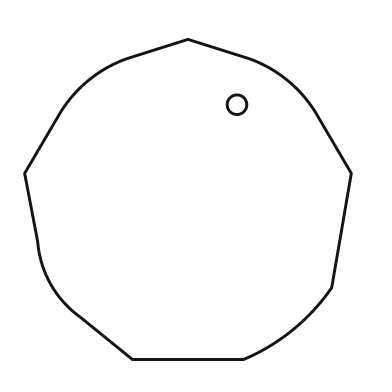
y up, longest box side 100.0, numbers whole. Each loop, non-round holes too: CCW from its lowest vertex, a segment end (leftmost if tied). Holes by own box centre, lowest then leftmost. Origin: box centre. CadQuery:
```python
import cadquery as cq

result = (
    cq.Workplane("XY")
    .moveTo(-17.0, -49.0)
    .lineTo(17.0, -49.0)
    .threePointArc((32.0, -40.0), (44.0, -27.0))
    .lineTo(50.0, 8.0)
    .lineTo(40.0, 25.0)
    .threePointArc((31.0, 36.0), (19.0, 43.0))
    .lineTo(0.0, 49.0)
    .lineTo(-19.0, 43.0)
    .threePointArc((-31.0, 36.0), (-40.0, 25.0))
    .lineTo(-50.0, 8.0)
    .lineTo(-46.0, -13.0)
    .threePointArc((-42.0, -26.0), (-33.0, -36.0))
    .close()
    .moveTo(15.0, 29.0)
    .circle(3.0)
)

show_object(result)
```